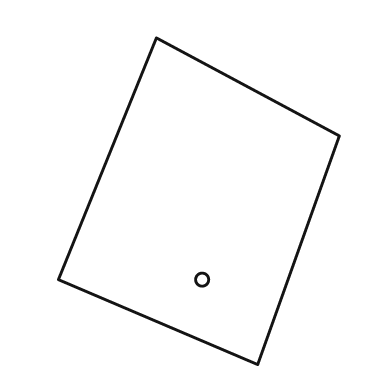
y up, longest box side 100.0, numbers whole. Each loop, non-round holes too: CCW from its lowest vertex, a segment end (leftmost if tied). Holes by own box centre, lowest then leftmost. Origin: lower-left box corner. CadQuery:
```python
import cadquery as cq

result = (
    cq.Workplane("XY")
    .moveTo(61.0, 0.0)
    .lineTo(86.0, 70.0)
    .lineTo(30.0, 100.0)
    .lineTo(0.0, 26.0)
    .close()
    .moveTo(44.0, 26.0)
    .circle(2.0)
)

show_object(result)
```